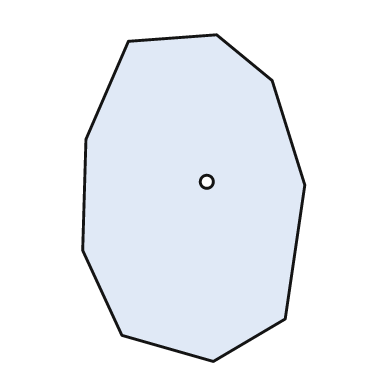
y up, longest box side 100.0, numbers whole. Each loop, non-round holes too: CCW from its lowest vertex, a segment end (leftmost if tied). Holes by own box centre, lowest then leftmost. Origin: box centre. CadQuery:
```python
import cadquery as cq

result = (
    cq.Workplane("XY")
    .moveTo(6.0, -50.0)
    .lineTo(28.0, -37.0)
    .lineTo(34.0, 4.0)
    .lineTo(24.0, 36.0)
    .lineTo(7.0, 50.0)
    .lineTo(-20.0, 48.0)
    .lineTo(-33.0, 18.0)
    .lineTo(-34.0, -16.0)
    .lineTo(-22.0, -42.0)
    .close()
    .moveTo(4.0, 5.0)
    .circle(2.0)
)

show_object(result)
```